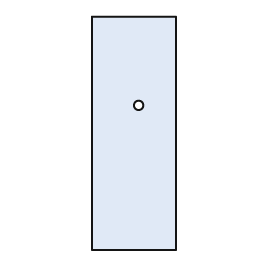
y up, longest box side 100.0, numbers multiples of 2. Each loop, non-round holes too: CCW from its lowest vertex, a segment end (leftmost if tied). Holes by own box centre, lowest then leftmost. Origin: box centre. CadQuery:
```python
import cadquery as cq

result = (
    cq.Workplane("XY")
    .moveTo(-18.0, -50.0)
    .lineTo(18.0, -50.0)
    .lineTo(18.0, 50.0)
    .lineTo(-18.0, 50.0)
    .close()
    .moveTo(2.0, 12.0)
    .circle(2.0)
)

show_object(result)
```